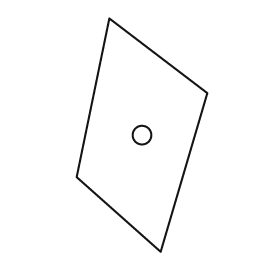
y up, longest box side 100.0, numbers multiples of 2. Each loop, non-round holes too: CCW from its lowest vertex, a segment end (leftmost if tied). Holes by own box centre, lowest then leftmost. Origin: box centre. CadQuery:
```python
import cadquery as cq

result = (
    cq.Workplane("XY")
    .moveTo(8.0, -50.0)
    .lineTo(28.0, 18.0)
    .lineTo(-14.0, 50.0)
    .lineTo(-28.0, -18.0)
    .close()
    .moveTo(0.0, 0.0)
    .circle(4.0)
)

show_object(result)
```